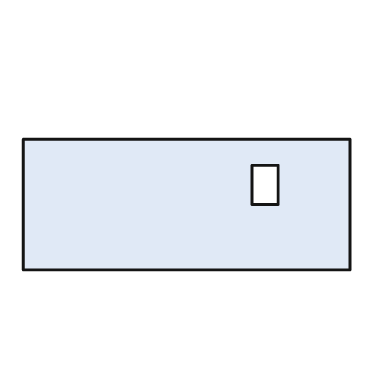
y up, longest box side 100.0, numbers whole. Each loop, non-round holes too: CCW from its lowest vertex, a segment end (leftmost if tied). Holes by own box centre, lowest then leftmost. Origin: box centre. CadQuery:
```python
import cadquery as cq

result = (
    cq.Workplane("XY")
    .moveTo(-50.0, -20.0)
    .lineTo(50.0, -20.0)
    .lineTo(50.0, 20.0)
    .lineTo(-50.0, 20.0)
    .close()
    .moveTo(20.0, 0.0)
    .lineTo(28.0, 0.0)
    .lineTo(28.0, 12.0)
    .lineTo(20.0, 12.0)
    .close()
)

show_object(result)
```